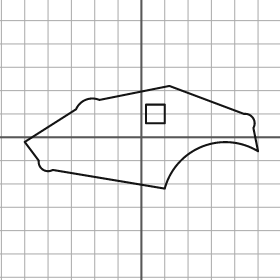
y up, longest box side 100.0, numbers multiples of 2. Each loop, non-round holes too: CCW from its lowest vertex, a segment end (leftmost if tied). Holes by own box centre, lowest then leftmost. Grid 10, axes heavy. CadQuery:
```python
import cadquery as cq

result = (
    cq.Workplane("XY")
    .moveTo(10.0, -22.0)
    .threePointArc((26.0, -4.0), (50.0, -6.0))
    .lineTo(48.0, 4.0)
    .threePointArc((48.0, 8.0), (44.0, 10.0))
    .lineTo(12.0, 22.0)
    .lineTo(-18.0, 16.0)
    .threePointArc((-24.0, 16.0), (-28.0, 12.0))
    .lineTo(-50.0, -2.0)
    .lineTo(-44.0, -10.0)
    .threePointArc((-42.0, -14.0), (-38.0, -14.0))
    .close()
    .moveTo(2.0, 6.0)
    .lineTo(10.0, 6.0)
    .lineTo(10.0, 14.0)
    .lineTo(2.0, 14.0)
    .close()
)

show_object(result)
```